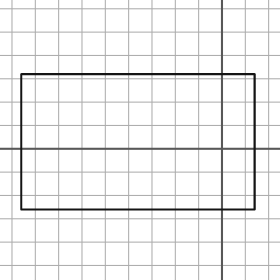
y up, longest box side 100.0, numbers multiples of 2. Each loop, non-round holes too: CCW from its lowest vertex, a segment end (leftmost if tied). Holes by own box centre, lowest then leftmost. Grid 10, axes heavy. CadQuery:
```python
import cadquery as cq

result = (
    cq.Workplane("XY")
    .moveTo(-86.0, -26.0)
    .lineTo(14.0, -26.0)
    .lineTo(14.0, 32.0)
    .lineTo(-86.0, 32.0)
    .close()
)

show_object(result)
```